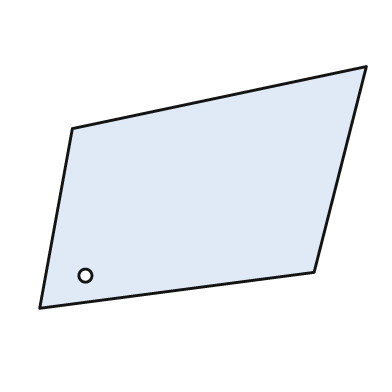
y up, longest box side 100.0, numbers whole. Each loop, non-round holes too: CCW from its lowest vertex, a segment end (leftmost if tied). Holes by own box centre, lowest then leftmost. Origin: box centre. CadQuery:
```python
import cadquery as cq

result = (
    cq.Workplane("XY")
    .moveTo(-50.0, -37.0)
    .lineTo(34.0, -26.0)
    .lineTo(50.0, 37.0)
    .lineTo(-40.0, 18.0)
    .close()
    .moveTo(-36.0, -27.0)
    .circle(2.0)
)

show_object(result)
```